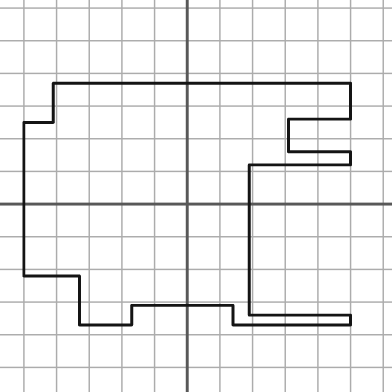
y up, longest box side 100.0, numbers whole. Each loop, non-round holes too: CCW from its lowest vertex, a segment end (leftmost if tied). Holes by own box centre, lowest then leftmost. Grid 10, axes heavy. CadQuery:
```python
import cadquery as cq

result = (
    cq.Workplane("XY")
    .moveTo(-33.0, -37.0)
    .lineTo(-17.0, -37.0)
    .lineTo(-17.0, -31.0)
    .lineTo(14.0, -31.0)
    .lineTo(14.0, -37.0)
    .lineTo(50.0, -37.0)
    .lineTo(50.0, -34.0)
    .lineTo(19.0, -34.0)
    .lineTo(19.0, 12.0)
    .lineTo(50.0, 12.0)
    .lineTo(50.0, 16.0)
    .lineTo(31.0, 16.0)
    .lineTo(31.0, 26.0)
    .lineTo(50.0, 26.0)
    .lineTo(50.0, 37.0)
    .lineTo(-41.0, 37.0)
    .lineTo(-41.0, 25.0)
    .lineTo(-50.0, 25.0)
    .lineTo(-50.0, -22.0)
    .lineTo(-33.0, -22.0)
    .close()
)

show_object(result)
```